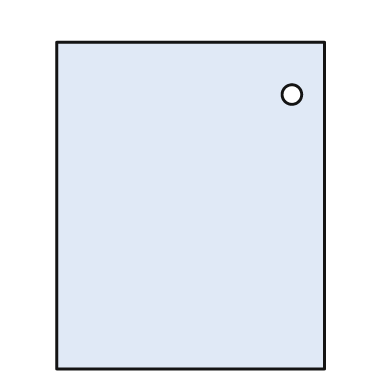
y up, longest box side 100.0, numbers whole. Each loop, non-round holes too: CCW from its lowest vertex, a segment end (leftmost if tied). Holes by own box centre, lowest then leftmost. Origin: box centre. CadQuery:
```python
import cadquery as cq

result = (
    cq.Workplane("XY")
    .moveTo(-41.0, -50.0)
    .lineTo(41.0, -50.0)
    .lineTo(41.0, 50.0)
    .lineTo(-41.0, 50.0)
    .close()
    .moveTo(31.0, 34.0)
    .circle(3.0)
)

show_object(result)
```